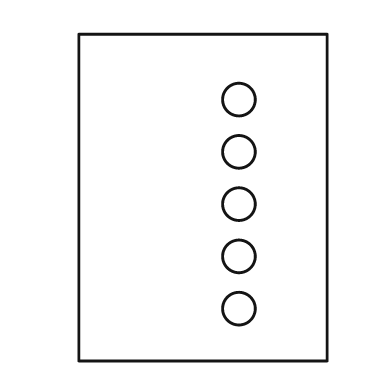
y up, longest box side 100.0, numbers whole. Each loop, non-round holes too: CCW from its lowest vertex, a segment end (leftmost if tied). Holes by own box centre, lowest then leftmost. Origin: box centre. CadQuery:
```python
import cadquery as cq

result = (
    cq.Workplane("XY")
    .moveTo(-38.0, -50.0)
    .lineTo(38.0, -50.0)
    .lineTo(38.0, 50.0)
    .lineTo(-38.0, 50.0)
    .close()
    .moveTo(11.0, -34.0)
    .circle(5.0)
    .moveTo(11.0, -18.0)
    .circle(5.0)
    .moveTo(11.0, -2.0)
    .circle(5.0)
    .moveTo(11.0, 14.0)
    .circle(5.0)
    .moveTo(11.0, 30.0)
    .circle(5.0)
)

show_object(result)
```